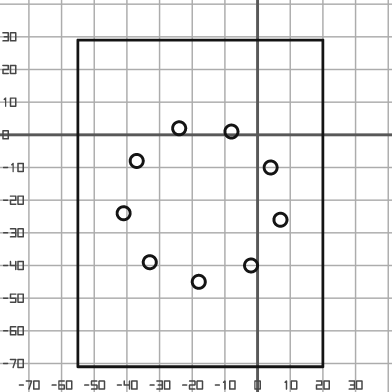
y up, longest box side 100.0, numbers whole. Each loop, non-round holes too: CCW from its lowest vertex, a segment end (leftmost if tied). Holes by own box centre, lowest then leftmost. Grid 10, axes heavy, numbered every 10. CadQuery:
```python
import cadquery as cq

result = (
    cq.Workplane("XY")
    .moveTo(-55.0, -71.0)
    .lineTo(20.0, -71.0)
    .lineTo(20.0, 29.0)
    .lineTo(-55.0, 29.0)
    .close()
    .moveTo(-18.0, -45.0)
    .circle(2.0)
    .moveTo(-2.0, -40.0)
    .circle(2.0)
    .moveTo(-33.0, -39.0)
    .circle(2.0)
    .moveTo(7.0, -26.0)
    .circle(2.0)
    .moveTo(-41.0, -24.0)
    .circle(2.0)
    .moveTo(4.0, -10.0)
    .circle(2.0)
    .moveTo(-37.0, -8.0)
    .circle(2.0)
    .moveTo(-8.0, 1.0)
    .circle(2.0)
    .moveTo(-24.0, 2.0)
    .circle(2.0)
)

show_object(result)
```